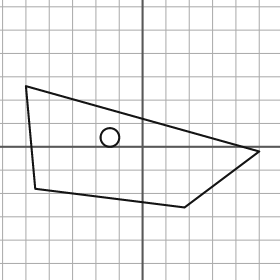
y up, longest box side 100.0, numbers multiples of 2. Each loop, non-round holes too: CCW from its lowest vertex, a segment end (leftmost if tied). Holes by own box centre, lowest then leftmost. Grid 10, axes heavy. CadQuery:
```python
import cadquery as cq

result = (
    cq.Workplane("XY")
    .moveTo(18.0, -26.0)
    .lineTo(50.0, -2.0)
    .lineTo(-50.0, 26.0)
    .lineTo(-46.0, -18.0)
    .close()
    .moveTo(-14.0, 4.0)
    .circle(4.0)
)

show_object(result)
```